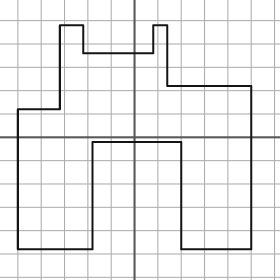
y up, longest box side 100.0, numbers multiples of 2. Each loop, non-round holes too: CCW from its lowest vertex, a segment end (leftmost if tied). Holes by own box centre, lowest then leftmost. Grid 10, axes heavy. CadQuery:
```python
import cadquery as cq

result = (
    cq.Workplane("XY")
    .moveTo(-50.0, -48.0)
    .lineTo(-18.0, -48.0)
    .lineTo(-18.0, -2.0)
    .lineTo(20.0, -2.0)
    .lineTo(20.0, -48.0)
    .lineTo(50.0, -48.0)
    .lineTo(50.0, 22.0)
    .lineTo(14.0, 22.0)
    .lineTo(14.0, 48.0)
    .lineTo(8.0, 48.0)
    .lineTo(8.0, 36.0)
    .lineTo(-22.0, 36.0)
    .lineTo(-22.0, 48.0)
    .lineTo(-32.0, 48.0)
    .lineTo(-32.0, 12.0)
    .lineTo(-50.0, 12.0)
    .close()
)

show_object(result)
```